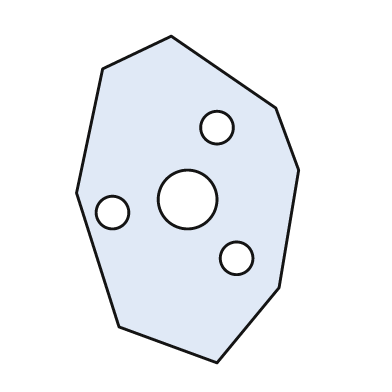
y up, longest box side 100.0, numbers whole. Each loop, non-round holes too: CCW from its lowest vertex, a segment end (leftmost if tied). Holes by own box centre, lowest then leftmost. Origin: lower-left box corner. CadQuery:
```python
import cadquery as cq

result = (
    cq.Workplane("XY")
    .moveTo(43.0, 0.0)
    .lineTo(62.0, 23.0)
    .lineTo(68.0, 59.0)
    .lineTo(61.0, 78.0)
    .lineTo(29.0, 100.0)
    .lineTo(8.0, 90.0)
    .lineTo(0.0, 52.0)
    .lineTo(13.0, 11.0)
    .close()
    .moveTo(49.0, 32.0)
    .circle(5.0)
    .moveTo(11.0, 46.0)
    .circle(5.0)
    .moveTo(34.0, 50.0)
    .circle(9.0)
    .moveTo(43.0, 72.0)
    .circle(5.0)
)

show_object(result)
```